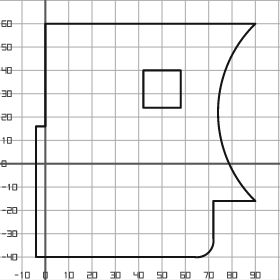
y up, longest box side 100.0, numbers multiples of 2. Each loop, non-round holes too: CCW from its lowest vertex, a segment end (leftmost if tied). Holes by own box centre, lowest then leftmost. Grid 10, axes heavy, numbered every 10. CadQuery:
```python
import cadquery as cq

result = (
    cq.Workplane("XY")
    .moveTo(-4.0, -40.0)
    .lineTo(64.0, -40.0)
    .threePointArc((70.0, -38.0), (72.0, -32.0))
    .lineTo(72.0, -16.0)
    .lineTo(90.0, -16.0)
    .threePointArc((74.0, 22.0), (90.0, 60.0))
    .lineTo(0.0, 60.0)
    .lineTo(0.0, 16.0)
    .lineTo(-4.0, 16.0)
    .close()
    .moveTo(42.0, 24.0)
    .lineTo(58.0, 24.0)
    .lineTo(58.0, 40.0)
    .lineTo(42.0, 40.0)
    .close()
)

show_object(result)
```